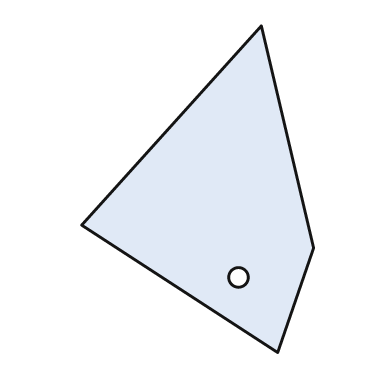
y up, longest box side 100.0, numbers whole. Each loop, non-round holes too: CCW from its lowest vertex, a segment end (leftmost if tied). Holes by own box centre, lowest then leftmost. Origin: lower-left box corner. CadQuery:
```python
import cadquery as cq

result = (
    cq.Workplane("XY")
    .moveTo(60.0, 0.0)
    .lineTo(71.0, 32.0)
    .lineTo(55.0, 100.0)
    .lineTo(0.0, 39.0)
    .close()
    .moveTo(48.0, 23.0)
    .circle(3.0)
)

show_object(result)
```